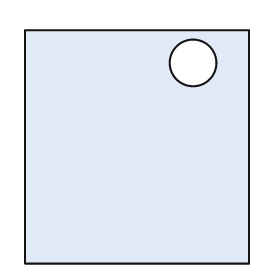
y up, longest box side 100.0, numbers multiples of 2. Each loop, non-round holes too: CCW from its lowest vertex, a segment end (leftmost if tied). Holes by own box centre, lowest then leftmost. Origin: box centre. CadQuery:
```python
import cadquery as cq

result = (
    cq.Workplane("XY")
    .moveTo(-48.0, -50.0)
    .lineTo(48.0, -50.0)
    .lineTo(48.0, 50.0)
    .lineTo(-48.0, 50.0)
    .close()
    .moveTo(24.0, 36.0)
    .circle(10.0)
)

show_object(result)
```